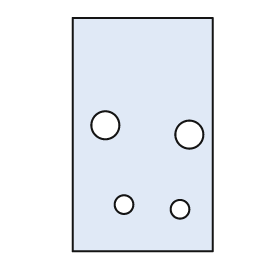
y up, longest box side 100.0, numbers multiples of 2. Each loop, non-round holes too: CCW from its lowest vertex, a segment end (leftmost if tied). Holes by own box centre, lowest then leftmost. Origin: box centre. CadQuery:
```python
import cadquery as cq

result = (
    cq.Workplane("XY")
    .moveTo(-30.0, -50.0)
    .lineTo(30.0, -50.0)
    .lineTo(30.0, 50.0)
    .lineTo(-30.0, 50.0)
    .close()
    .moveTo(16.0, -32.0)
    .circle(4.0)
    .moveTo(-8.0, -30.0)
    .circle(4.0)
    .moveTo(20.0, 0.0)
    .circle(6.0)
    .moveTo(-16.0, 4.0)
    .circle(6.0)
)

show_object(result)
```